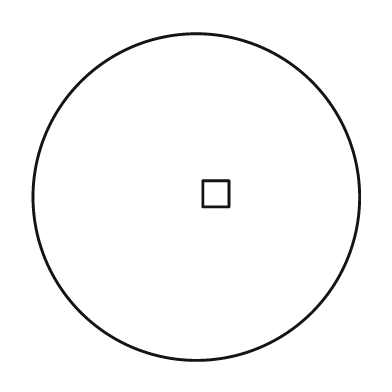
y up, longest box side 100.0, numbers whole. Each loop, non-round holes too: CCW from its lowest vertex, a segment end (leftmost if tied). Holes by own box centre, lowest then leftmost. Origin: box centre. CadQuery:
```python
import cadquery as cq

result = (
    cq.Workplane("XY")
    .moveTo(0.0, 0.0)
    .circle(50.0)
    .moveTo(2.0, -3.0)
    .lineTo(10.0, -3.0)
    .lineTo(10.0, 5.0)
    .lineTo(2.0, 5.0)
    .close()
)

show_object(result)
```